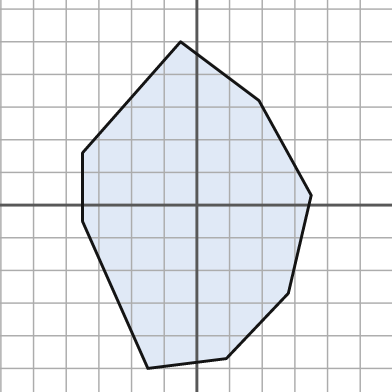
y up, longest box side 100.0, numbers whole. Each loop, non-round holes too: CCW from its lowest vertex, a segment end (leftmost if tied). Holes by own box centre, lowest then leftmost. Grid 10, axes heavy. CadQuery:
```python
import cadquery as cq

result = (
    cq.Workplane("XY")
    .moveTo(-15.0, -50.0)
    .lineTo(9.0, -47.0)
    .lineTo(28.0, -27.0)
    .lineTo(35.0, 3.0)
    .lineTo(19.0, 32.0)
    .lineTo(-5.0, 50.0)
    .lineTo(-35.0, 16.0)
    .lineTo(-35.0, -5.0)
    .close()
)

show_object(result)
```